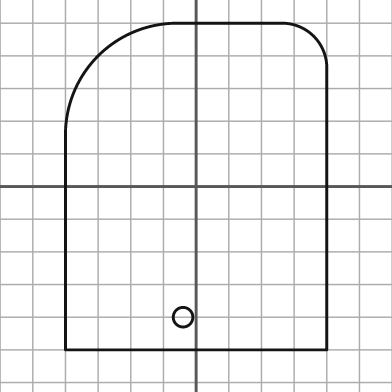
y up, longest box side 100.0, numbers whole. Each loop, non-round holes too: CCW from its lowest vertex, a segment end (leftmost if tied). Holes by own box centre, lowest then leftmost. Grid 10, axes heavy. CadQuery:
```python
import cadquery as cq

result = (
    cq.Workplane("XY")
    .moveTo(-40.0, -50.0)
    .lineTo(40.0, -50.0)
    .lineTo(40.0, 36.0)
    .threePointArc((36.0, 46.0), (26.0, 50.0))
    .lineTo(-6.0, 50.0)
    .threePointArc((-30.0, 40.0), (-40.0, 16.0))
    .close()
    .moveTo(-4.0, -40.0)
    .circle(3.0)
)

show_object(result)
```